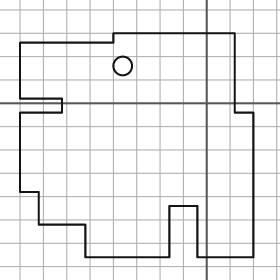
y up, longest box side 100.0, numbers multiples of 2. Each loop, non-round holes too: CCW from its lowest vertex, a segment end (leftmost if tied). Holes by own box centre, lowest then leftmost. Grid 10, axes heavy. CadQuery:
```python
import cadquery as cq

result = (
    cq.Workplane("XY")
    .moveTo(-52.0, -66.0)
    .lineTo(-16.0, -66.0)
    .lineTo(-16.0, -44.0)
    .lineTo(-4.0, -44.0)
    .lineTo(-4.0, -66.0)
    .lineTo(20.0, -66.0)
    .lineTo(20.0, -4.0)
    .lineTo(12.0, -4.0)
    .lineTo(12.0, 30.0)
    .lineTo(-40.0, 30.0)
    .lineTo(-40.0, 26.0)
    .lineTo(-80.0, 26.0)
    .lineTo(-80.0, 2.0)
    .lineTo(-62.0, 2.0)
    .lineTo(-62.0, -4.0)
    .lineTo(-80.0, -4.0)
    .lineTo(-80.0, -38.0)
    .lineTo(-72.0, -38.0)
    .lineTo(-72.0, -52.0)
    .lineTo(-52.0, -52.0)
    .close()
    .moveTo(-36.0, 16.0)
    .circle(4.0)
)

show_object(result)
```